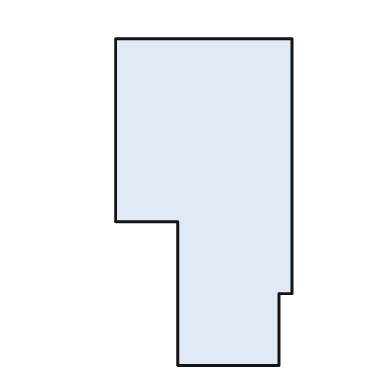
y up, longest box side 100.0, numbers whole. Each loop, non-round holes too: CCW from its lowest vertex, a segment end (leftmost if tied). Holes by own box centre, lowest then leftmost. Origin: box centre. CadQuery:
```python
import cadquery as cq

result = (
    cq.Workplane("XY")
    .moveTo(-8.0, -50.0)
    .lineTo(23.0, -50.0)
    .lineTo(23.0, -28.0)
    .lineTo(27.0, -28.0)
    .lineTo(27.0, 50.0)
    .lineTo(-27.0, 50.0)
    .lineTo(-27.0, -6.0)
    .lineTo(-8.0, -6.0)
    .close()
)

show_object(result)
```